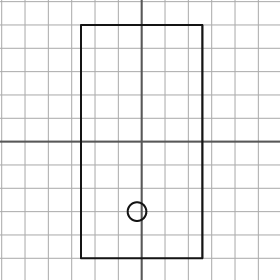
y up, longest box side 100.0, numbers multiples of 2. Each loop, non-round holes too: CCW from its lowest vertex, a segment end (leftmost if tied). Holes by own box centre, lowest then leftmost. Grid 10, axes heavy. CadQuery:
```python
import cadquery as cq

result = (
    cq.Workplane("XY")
    .moveTo(-26.0, -50.0)
    .lineTo(26.0, -50.0)
    .lineTo(26.0, 50.0)
    .lineTo(-26.0, 50.0)
    .close()
    .moveTo(-2.0, -30.0)
    .circle(4.0)
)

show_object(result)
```